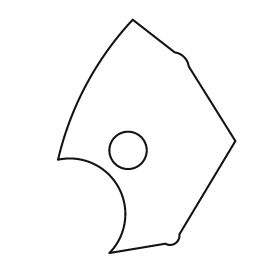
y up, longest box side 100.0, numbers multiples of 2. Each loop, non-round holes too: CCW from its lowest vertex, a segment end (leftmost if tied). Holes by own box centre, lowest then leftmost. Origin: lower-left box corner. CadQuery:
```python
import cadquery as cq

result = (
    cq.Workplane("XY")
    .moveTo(22.0, 0.0)
    .lineTo(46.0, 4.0)
    .threePointArc((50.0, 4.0), (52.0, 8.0))
    .lineTo(76.0, 48.0)
    .lineTo(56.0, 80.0)
    .threePointArc((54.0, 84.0), (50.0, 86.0))
    .lineTo(32.0, 100.0)
    .threePointArc((12.0, 72.0), (0.0, 40.0))
    .threePointArc((26.0, 28.0), (22.0, 0.0))
    .close()
    .moveTo(30.0, 44.0)
    .circle(8.0)
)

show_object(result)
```